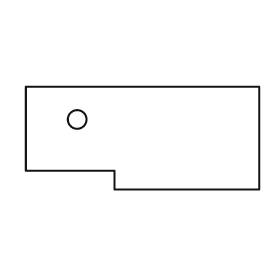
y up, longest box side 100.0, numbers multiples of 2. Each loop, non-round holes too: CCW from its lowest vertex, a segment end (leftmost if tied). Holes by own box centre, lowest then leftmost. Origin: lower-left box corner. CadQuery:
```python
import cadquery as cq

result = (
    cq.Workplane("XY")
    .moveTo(38.0, 0.0)
    .lineTo(100.0, 0.0)
    .lineTo(100.0, 44.0)
    .lineTo(0.0, 44.0)
    .lineTo(0.0, 8.0)
    .lineTo(38.0, 8.0)
    .close()
    .moveTo(22.0, 30.0)
    .circle(4.0)
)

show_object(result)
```